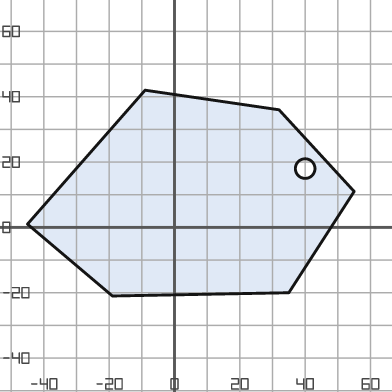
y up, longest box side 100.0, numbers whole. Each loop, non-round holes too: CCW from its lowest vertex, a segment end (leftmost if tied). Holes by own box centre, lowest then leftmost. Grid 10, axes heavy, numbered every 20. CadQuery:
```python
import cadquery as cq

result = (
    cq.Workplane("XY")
    .moveTo(-19.0, -21.0)
    .lineTo(35.0, -20.0)
    .lineTo(55.0, 11.0)
    .lineTo(32.0, 36.0)
    .lineTo(-9.0, 42.0)
    .lineTo(-45.0, 1.0)
    .close()
    .moveTo(40.0, 18.0)
    .circle(3.0)
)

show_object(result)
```